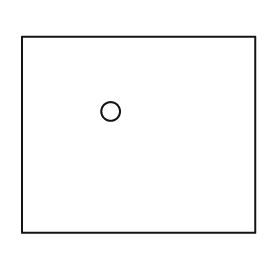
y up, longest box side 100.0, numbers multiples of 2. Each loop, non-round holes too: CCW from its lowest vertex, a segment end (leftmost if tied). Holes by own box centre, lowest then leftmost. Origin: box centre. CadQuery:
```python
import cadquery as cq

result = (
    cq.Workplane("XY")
    .moveTo(-50.0, -42.0)
    .lineTo(50.0, -42.0)
    .lineTo(50.0, 42.0)
    .lineTo(-50.0, 42.0)
    .close()
    .moveTo(-12.0, 10.0)
    .circle(4.0)
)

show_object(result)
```